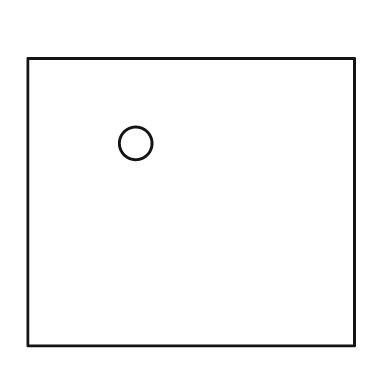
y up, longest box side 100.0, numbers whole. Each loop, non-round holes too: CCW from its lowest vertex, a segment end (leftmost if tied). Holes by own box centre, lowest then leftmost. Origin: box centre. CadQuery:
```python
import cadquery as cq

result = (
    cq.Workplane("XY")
    .moveTo(-50.0, -44.0)
    .lineTo(50.0, -44.0)
    .lineTo(50.0, 44.0)
    .lineTo(-50.0, 44.0)
    .close()
    .moveTo(-17.0, 18.0)
    .circle(5.0)
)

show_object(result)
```